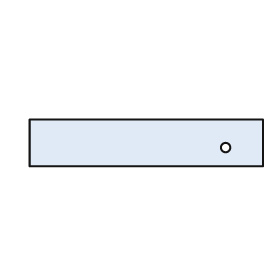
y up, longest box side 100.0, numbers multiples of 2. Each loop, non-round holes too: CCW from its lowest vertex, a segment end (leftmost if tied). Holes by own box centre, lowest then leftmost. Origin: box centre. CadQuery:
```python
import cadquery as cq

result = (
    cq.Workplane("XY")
    .moveTo(-50.0, -10.0)
    .lineTo(50.0, -10.0)
    .lineTo(50.0, 10.0)
    .lineTo(-50.0, 10.0)
    .close()
    .moveTo(34.0, -2.0)
    .circle(2.0)
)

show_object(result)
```